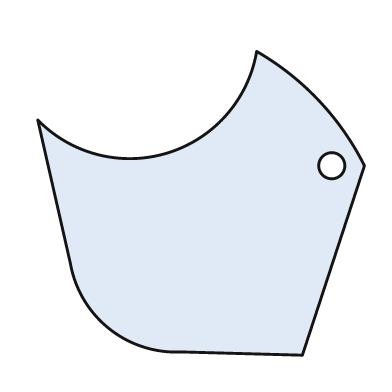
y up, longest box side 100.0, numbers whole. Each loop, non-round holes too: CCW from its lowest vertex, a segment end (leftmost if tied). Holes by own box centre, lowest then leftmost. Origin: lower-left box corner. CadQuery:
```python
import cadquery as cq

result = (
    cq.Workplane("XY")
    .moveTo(81.0, 0.0)
    .lineTo(100.0, 58.0)
    .threePointArc((86.0, 78.0), (67.0, 93.0))
    .threePointArc((40.0, 62.0), (0.0, 72.0))
    .lineTo(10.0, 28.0)
    .threePointArc((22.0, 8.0), (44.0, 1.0))
    .close()
    .moveTo(90.0, 58.0)
    .circle(4.0)
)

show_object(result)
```